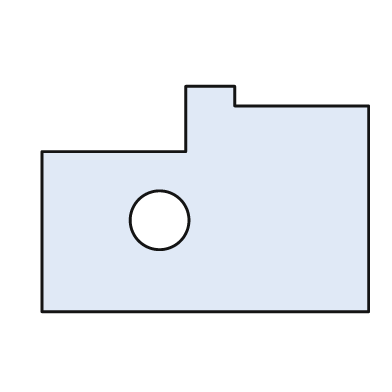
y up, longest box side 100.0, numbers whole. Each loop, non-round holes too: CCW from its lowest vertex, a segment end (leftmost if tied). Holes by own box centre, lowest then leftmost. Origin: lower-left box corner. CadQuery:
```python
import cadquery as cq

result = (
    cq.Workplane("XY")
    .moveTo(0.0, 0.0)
    .lineTo(100.0, 0.0)
    .lineTo(100.0, 63.0)
    .lineTo(59.0, 63.0)
    .lineTo(59.0, 69.0)
    .lineTo(44.0, 69.0)
    .lineTo(44.0, 49.0)
    .lineTo(0.0, 49.0)
    .close()
    .moveTo(36.0, 28.0)
    .circle(9.0)
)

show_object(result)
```